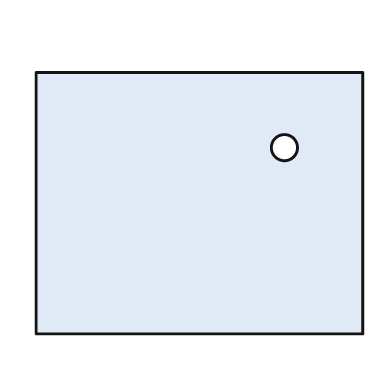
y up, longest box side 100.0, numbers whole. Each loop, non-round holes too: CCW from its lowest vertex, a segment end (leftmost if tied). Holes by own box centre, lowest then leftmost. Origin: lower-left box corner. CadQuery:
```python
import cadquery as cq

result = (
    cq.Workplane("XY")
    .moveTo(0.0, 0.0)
    .lineTo(100.0, 0.0)
    .lineTo(100.0, 80.0)
    .lineTo(0.0, 80.0)
    .close()
    .moveTo(76.0, 57.0)
    .circle(4.0)
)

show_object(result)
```